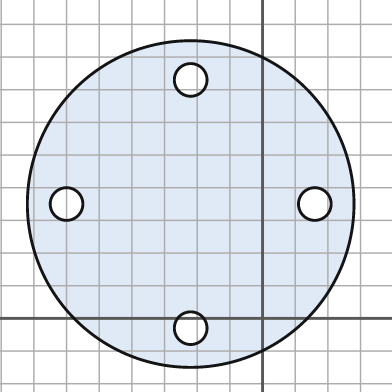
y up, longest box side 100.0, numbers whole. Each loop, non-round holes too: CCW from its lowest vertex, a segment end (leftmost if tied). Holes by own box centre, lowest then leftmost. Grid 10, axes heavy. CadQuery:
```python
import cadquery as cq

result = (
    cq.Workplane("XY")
    .moveTo(-22.0, 35.0)
    .circle(50.0)
    .moveTo(-22.0, -3.0)
    .circle(5.0)
    .moveTo(-60.0, 35.0)
    .circle(5.0)
    .moveTo(16.0, 35.0)
    .circle(5.0)
    .moveTo(-22.0, 73.0)
    .circle(5.0)
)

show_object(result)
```